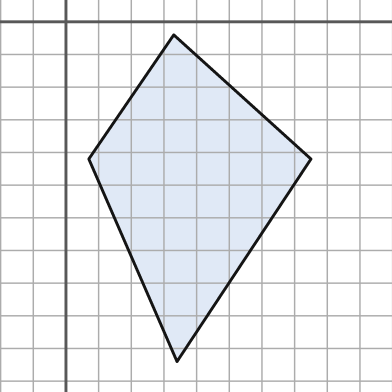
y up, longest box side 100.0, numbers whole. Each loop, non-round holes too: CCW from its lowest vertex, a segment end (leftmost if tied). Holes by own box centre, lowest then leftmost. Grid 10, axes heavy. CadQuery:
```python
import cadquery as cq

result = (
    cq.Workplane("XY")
    .moveTo(34.0, -104.0)
    .lineTo(75.0, -42.0)
    .lineTo(33.0, -4.0)
    .lineTo(7.0, -42.0)
    .close()
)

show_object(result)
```